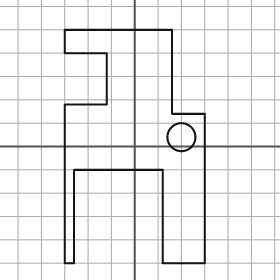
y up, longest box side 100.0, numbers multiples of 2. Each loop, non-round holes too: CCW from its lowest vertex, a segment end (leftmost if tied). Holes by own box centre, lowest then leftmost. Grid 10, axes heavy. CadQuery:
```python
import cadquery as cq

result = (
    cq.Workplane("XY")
    .moveTo(-30.0, -50.0)
    .lineTo(-26.0, -50.0)
    .lineTo(-26.0, -10.0)
    .lineTo(12.0, -10.0)
    .lineTo(12.0, -50.0)
    .lineTo(30.0, -50.0)
    .lineTo(30.0, 14.0)
    .lineTo(16.0, 14.0)
    .lineTo(16.0, 50.0)
    .lineTo(-30.0, 50.0)
    .lineTo(-30.0, 40.0)
    .lineTo(-12.0, 40.0)
    .lineTo(-12.0, 18.0)
    .lineTo(-30.0, 18.0)
    .close()
    .moveTo(20.0, 4.0)
    .circle(6.0)
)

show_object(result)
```